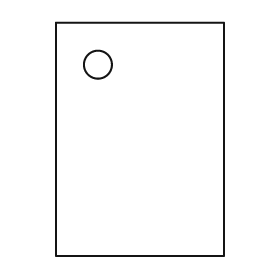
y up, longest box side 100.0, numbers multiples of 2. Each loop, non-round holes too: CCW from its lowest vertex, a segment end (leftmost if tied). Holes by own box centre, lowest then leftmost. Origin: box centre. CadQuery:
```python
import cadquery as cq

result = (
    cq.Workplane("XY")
    .moveTo(-36.0, -50.0)
    .lineTo(36.0, -50.0)
    .lineTo(36.0, 50.0)
    .lineTo(-36.0, 50.0)
    .close()
    .moveTo(-18.0, 32.0)
    .circle(6.0)
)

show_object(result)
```